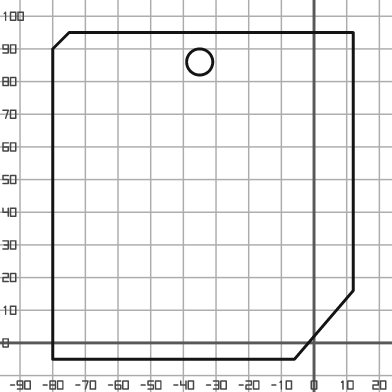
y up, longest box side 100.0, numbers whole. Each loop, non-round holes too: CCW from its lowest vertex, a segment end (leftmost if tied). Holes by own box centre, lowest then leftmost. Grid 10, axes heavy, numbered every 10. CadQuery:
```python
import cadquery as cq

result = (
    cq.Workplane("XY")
    .moveTo(-80.0, -5.0)
    .lineTo(-6.0, -5.0)
    .lineTo(12.0, 16.0)
    .lineTo(12.0, 95.0)
    .lineTo(-75.0, 95.0)
    .lineTo(-80.0, 90.0)
    .close()
    .moveTo(-35.0, 86.0)
    .circle(4.0)
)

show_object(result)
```